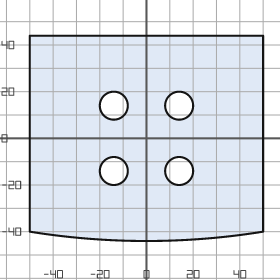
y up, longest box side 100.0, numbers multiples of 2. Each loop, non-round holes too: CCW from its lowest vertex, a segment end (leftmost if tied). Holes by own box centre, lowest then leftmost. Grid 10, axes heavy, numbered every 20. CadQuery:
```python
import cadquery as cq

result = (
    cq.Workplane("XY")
    .moveTo(-50.0, -40.0)
    .threePointArc((0.0, -44.0), (50.0, -40.0))
    .lineTo(50.0, 44.0)
    .lineTo(-50.0, 44.0)
    .close()
    .moveTo(-14.0, -14.0)
    .circle(6.0)
    .moveTo(14.0, -14.0)
    .circle(6.0)
    .moveTo(-14.0, 14.0)
    .circle(6.0)
    .moveTo(14.0, 14.0)
    .circle(6.0)
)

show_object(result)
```